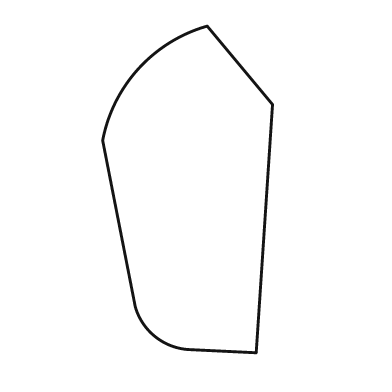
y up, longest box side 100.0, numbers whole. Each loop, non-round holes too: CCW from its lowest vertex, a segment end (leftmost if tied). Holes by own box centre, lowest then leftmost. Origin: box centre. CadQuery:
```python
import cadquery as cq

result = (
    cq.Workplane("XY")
    .moveTo(21.0, -50.0)
    .lineTo(26.0, 26.0)
    .lineTo(6.0, 50.0)
    .threePointArc((-15.0, 37.0), (-26.0, 15.0))
    .lineTo(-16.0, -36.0)
    .threePointArc((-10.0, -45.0), (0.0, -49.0))
    .close()
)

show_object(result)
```